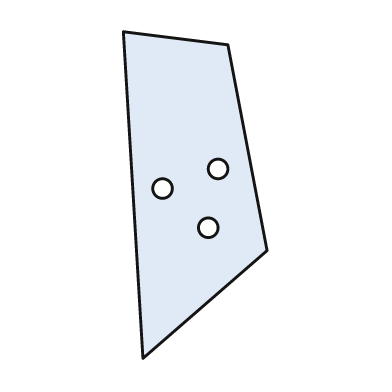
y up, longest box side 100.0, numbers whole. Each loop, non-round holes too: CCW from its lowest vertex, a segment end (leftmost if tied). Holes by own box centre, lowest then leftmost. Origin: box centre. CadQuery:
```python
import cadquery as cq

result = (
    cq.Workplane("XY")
    .moveTo(-16.0, -50.0)
    .lineTo(22.0, -17.0)
    .lineTo(10.0, 46.0)
    .lineTo(-22.0, 50.0)
    .close()
    .moveTo(4.0, -10.0)
    .circle(3.0)
    .moveTo(-10.0, 2.0)
    .circle(3.0)
    .moveTo(7.0, 8.0)
    .circle(3.0)
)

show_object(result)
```